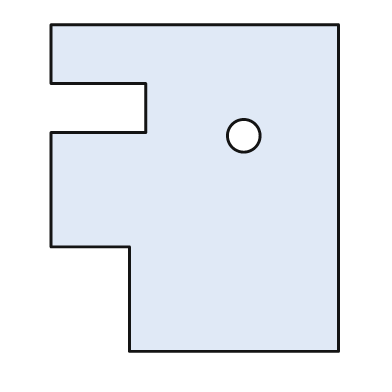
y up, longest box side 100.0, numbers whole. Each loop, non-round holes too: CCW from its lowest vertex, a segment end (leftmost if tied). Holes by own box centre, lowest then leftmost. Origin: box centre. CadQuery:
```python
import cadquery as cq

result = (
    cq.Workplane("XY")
    .moveTo(-20.0, -50.0)
    .lineTo(44.0, -50.0)
    .lineTo(44.0, 50.0)
    .lineTo(-44.0, 50.0)
    .lineTo(-44.0, 32.0)
    .lineTo(-15.0, 32.0)
    .lineTo(-15.0, 17.0)
    .lineTo(-44.0, 17.0)
    .lineTo(-44.0, -18.0)
    .lineTo(-20.0, -18.0)
    .close()
    .moveTo(15.0, 16.0)
    .circle(5.0)
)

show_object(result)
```